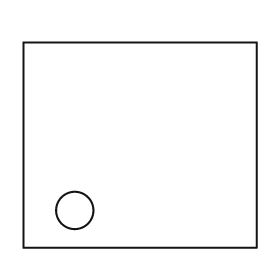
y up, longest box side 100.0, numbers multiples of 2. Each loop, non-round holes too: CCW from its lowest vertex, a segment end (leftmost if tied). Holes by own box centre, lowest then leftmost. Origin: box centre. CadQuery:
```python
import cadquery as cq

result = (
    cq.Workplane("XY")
    .moveTo(-50.0, -44.0)
    .lineTo(50.0, -44.0)
    .lineTo(50.0, 44.0)
    .lineTo(-50.0, 44.0)
    .close()
    .moveTo(-28.0, -28.0)
    .circle(8.0)
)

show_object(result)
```